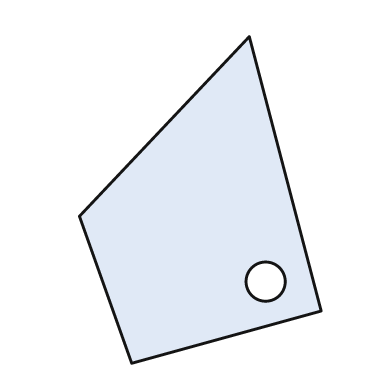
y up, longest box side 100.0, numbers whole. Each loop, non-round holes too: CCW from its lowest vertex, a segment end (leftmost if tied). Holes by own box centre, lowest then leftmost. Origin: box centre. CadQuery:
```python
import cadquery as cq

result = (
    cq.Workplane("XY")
    .moveTo(-21.0, -50.0)
    .lineTo(37.0, -34.0)
    .lineTo(15.0, 50.0)
    .lineTo(-37.0, -5.0)
    .close()
    .moveTo(20.0, -25.0)
    .circle(6.0)
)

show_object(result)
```